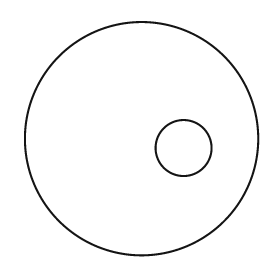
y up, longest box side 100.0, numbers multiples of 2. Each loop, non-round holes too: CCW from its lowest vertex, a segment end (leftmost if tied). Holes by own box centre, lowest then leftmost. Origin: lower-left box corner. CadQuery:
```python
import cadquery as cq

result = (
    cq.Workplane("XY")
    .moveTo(50.0, 50.0)
    .circle(50.0)
    .moveTo(68.0, 46.0)
    .circle(12.0)
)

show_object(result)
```